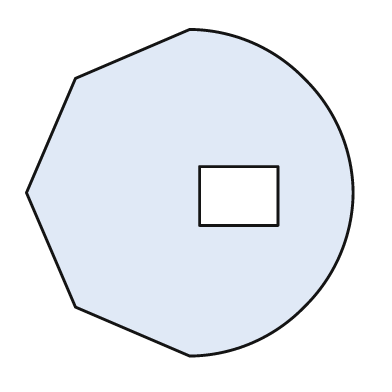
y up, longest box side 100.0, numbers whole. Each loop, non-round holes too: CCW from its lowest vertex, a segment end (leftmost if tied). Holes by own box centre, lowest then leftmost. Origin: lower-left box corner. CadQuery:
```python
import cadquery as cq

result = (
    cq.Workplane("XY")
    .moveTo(50.0, 0.0)
    .threePointArc((69.0, 4.0), (85.0, 15.0))
    .threePointArc((96.0, 31.0), (100.0, 50.0))
    .threePointArc((96.0, 69.0), (85.0, 85.0))
    .threePointArc((69.0, 96.0), (50.0, 100.0))
    .lineTo(15.0, 85.0)
    .lineTo(0.0, 50.0)
    .lineTo(15.0, 15.0)
    .close()
    .moveTo(53.0, 40.0)
    .lineTo(77.0, 40.0)
    .lineTo(77.0, 58.0)
    .lineTo(53.0, 58.0)
    .close()
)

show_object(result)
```